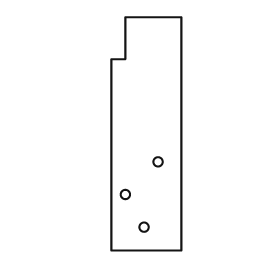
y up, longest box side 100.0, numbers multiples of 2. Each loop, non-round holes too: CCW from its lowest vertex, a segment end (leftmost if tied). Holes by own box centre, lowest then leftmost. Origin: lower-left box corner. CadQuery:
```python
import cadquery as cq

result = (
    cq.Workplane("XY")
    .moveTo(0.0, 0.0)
    .lineTo(30.0, 0.0)
    .lineTo(30.0, 100.0)
    .lineTo(6.0, 100.0)
    .lineTo(6.0, 82.0)
    .lineTo(0.0, 82.0)
    .close()
    .moveTo(14.0, 10.0)
    .circle(2.0)
    .moveTo(6.0, 24.0)
    .circle(2.0)
    .moveTo(20.0, 38.0)
    .circle(2.0)
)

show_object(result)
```